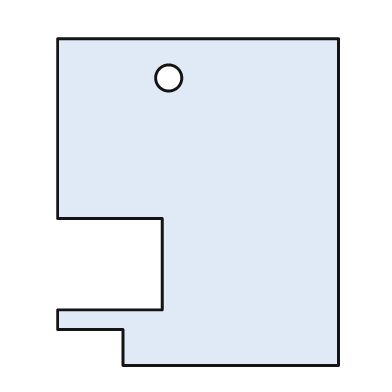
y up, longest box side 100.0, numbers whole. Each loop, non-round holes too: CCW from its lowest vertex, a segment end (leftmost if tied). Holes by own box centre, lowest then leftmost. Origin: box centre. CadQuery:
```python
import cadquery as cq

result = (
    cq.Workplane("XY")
    .moveTo(-23.0, -50.0)
    .lineTo(43.0, -50.0)
    .lineTo(43.0, 50.0)
    .lineTo(-43.0, 50.0)
    .lineTo(-43.0, -5.0)
    .lineTo(-11.0, -5.0)
    .lineTo(-11.0, -33.0)
    .lineTo(-43.0, -33.0)
    .lineTo(-43.0, -39.0)
    .lineTo(-23.0, -39.0)
    .close()
    .moveTo(-9.0, 38.0)
    .circle(4.0)
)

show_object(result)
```